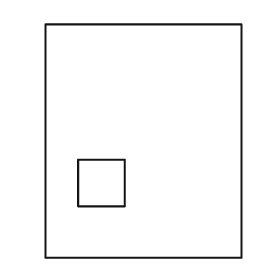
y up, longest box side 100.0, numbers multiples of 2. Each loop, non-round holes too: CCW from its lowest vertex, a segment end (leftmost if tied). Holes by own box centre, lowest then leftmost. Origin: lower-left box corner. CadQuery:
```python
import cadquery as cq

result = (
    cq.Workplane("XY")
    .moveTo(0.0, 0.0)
    .lineTo(84.0, 0.0)
    .lineTo(84.0, 100.0)
    .lineTo(0.0, 100.0)
    .close()
    .moveTo(14.0, 22.0)
    .lineTo(34.0, 22.0)
    .lineTo(34.0, 42.0)
    .lineTo(14.0, 42.0)
    .close()
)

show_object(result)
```